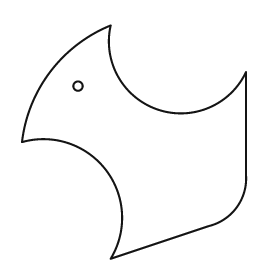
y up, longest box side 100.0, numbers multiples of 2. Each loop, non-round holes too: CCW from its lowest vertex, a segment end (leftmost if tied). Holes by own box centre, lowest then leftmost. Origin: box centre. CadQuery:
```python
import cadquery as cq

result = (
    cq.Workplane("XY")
    .moveTo(-10.0, -50.0)
    .lineTo(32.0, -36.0)
    .threePointArc((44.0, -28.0), (48.0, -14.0))
    .lineTo(48.0, 30.0)
    .threePointArc((10.0, 14.0), (-10.0, 50.0))
    .threePointArc((-36.0, 30.0), (-48.0, 0.0))
    .threePointArc((-12.0, -12.0), (-10.0, -50.0))
    .close()
    .moveTo(-24.0, 24.0)
    .circle(2.0)
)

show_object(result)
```